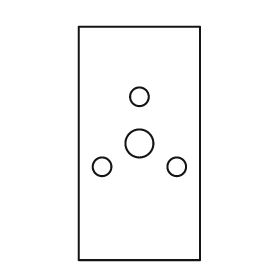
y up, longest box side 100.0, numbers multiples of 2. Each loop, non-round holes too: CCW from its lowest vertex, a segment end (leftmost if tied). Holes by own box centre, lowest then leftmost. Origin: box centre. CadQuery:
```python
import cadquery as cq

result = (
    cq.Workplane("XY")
    .moveTo(-26.0, -50.0)
    .lineTo(26.0, -50.0)
    .lineTo(26.0, 50.0)
    .lineTo(-26.0, 50.0)
    .close()
    .moveTo(-16.0, -10.0)
    .circle(4.0)
    .moveTo(16.0, -10.0)
    .circle(4.0)
    .moveTo(0.0, 0.0)
    .circle(6.0)
    .moveTo(0.0, 20.0)
    .circle(4.0)
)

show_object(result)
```